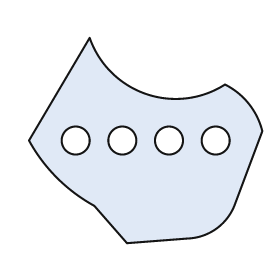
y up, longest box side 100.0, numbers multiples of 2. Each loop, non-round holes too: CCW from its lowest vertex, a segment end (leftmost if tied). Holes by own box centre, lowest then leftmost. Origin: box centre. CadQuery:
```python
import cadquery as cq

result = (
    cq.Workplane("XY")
    .moveTo(-8.0, -44.0)
    .lineTo(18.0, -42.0)
    .threePointArc((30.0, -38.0), (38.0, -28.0))
    .lineTo(50.0, 4.0)
    .threePointArc((44.0, 16.0), (34.0, 24.0))
    .threePointArc((0.0, 20.0), (-24.0, 44.0))
    .lineTo(-50.0, 0.0)
    .threePointArc((-38.0, -16.0), (-22.0, -28.0))
    .close()
    .moveTo(-30.0, 0.0)
    .circle(6.0)
    .moveTo(-10.0, 0.0)
    .circle(6.0)
    .moveTo(10.0, 0.0)
    .circle(6.0)
    .moveTo(30.0, 0.0)
    .circle(6.0)
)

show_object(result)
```